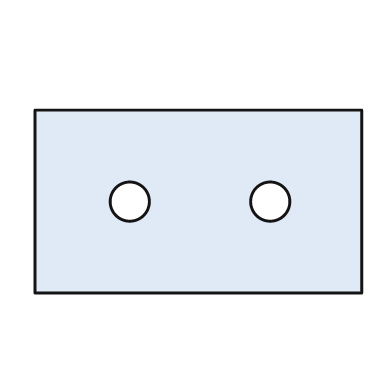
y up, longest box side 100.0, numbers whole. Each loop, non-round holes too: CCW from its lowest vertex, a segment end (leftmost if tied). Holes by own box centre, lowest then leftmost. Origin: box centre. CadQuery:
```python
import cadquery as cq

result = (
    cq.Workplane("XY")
    .moveTo(-50.0, -28.0)
    .lineTo(50.0, -28.0)
    .lineTo(50.0, 28.0)
    .lineTo(-50.0, 28.0)
    .close()
    .moveTo(-21.0, 0.0)
    .circle(6.0)
    .moveTo(22.0, 0.0)
    .circle(6.0)
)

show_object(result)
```